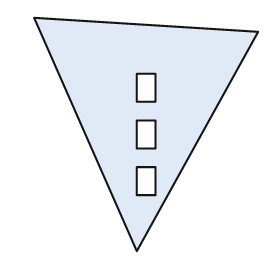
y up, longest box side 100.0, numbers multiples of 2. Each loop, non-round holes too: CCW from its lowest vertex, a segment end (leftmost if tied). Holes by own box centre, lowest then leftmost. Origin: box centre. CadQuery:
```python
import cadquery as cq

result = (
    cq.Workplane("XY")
    .moveTo(-4.0, -50.0)
    .lineTo(48.0, 44.0)
    .lineTo(-48.0, 50.0)
    .close()
    .moveTo(-4.0, -26.0)
    .lineTo(4.0, -26.0)
    .lineTo(4.0, -14.0)
    .lineTo(-4.0, -14.0)
    .close()
    .moveTo(-4.0, -6.0)
    .lineTo(4.0, -6.0)
    .lineTo(4.0, 6.0)
    .lineTo(-4.0, 6.0)
    .close()
    .moveTo(-4.0, 14.0)
    .lineTo(4.0, 14.0)
    .lineTo(4.0, 26.0)
    .lineTo(-4.0, 26.0)
    .close()
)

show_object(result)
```